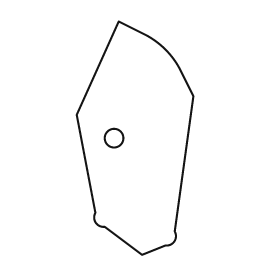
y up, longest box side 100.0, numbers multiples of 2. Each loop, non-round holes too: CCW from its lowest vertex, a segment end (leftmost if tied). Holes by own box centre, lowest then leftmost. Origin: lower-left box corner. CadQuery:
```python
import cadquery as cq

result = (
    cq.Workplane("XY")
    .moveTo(28.0, 0.0)
    .lineTo(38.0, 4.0)
    .threePointArc((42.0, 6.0), (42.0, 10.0))
    .lineTo(50.0, 68.0)
    .lineTo(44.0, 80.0)
    .threePointArc((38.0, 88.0), (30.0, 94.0))
    .lineTo(18.0, 100.0)
    .lineTo(0.0, 60.0)
    .lineTo(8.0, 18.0)
    .threePointArc((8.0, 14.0), (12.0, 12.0))
    .close()
    .moveTo(16.0, 50.0)
    .circle(4.0)
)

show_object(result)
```